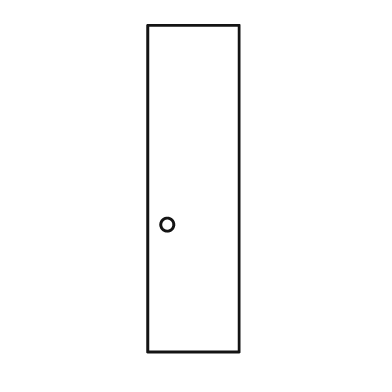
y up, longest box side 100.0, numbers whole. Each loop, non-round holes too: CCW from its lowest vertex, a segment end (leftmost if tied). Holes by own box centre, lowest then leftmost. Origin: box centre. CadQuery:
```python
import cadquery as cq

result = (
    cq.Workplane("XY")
    .moveTo(-14.0, -50.0)
    .lineTo(14.0, -50.0)
    .lineTo(14.0, 50.0)
    .lineTo(-14.0, 50.0)
    .close()
    .moveTo(-8.0, -11.0)
    .circle(2.0)
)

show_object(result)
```